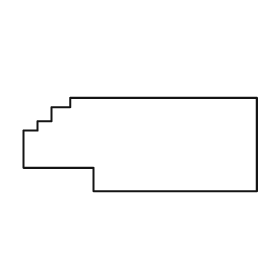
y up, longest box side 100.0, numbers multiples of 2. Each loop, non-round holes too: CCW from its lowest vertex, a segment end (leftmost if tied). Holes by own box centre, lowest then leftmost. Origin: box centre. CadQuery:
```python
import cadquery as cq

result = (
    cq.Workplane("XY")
    .moveTo(-20.0, -20.0)
    .lineTo(50.0, -20.0)
    .lineTo(50.0, 20.0)
    .lineTo(-30.0, 20.0)
    .lineTo(-30.0, 16.0)
    .lineTo(-38.0, 16.0)
    .lineTo(-38.0, 10.0)
    .lineTo(-44.0, 10.0)
    .lineTo(-44.0, 6.0)
    .lineTo(-50.0, 6.0)
    .lineTo(-50.0, -10.0)
    .lineTo(-20.0, -10.0)
    .close()
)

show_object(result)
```